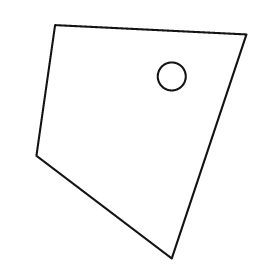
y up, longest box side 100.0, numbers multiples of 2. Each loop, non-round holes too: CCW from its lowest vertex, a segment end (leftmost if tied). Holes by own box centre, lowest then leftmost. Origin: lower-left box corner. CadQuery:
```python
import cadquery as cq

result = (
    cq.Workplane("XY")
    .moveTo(58.0, 0.0)
    .lineTo(90.0, 96.0)
    .lineTo(8.0, 100.0)
    .lineTo(0.0, 44.0)
    .close()
    .moveTo(58.0, 78.0)
    .circle(6.0)
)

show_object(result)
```